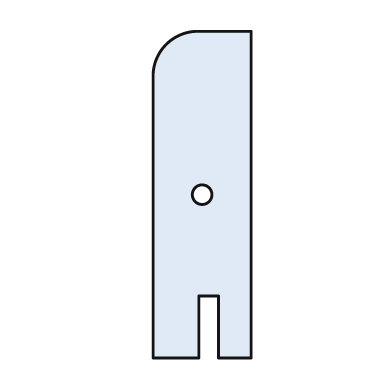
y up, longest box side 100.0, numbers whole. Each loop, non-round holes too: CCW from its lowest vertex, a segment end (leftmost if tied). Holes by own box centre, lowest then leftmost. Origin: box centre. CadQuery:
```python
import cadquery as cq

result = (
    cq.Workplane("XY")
    .moveTo(-15.0, -50.0)
    .lineTo(-1.0, -50.0)
    .lineTo(-1.0, -31.0)
    .lineTo(5.0, -31.0)
    .lineTo(5.0, -50.0)
    .lineTo(15.0, -50.0)
    .lineTo(15.0, 50.0)
    .lineTo(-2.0, 50.0)
    .threePointArc((-11.0, 46.0), (-15.0, 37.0))
    .close()
    .moveTo(0.0, 0.0)
    .circle(3.0)
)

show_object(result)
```